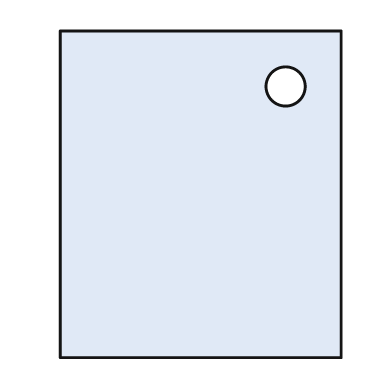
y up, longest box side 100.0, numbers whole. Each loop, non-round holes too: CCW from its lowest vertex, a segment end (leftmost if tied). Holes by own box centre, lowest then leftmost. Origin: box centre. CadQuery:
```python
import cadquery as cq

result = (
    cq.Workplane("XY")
    .moveTo(-43.0, -50.0)
    .lineTo(43.0, -50.0)
    .lineTo(43.0, 50.0)
    .lineTo(-43.0, 50.0)
    .close()
    .moveTo(26.0, 33.0)
    .circle(6.0)
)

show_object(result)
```